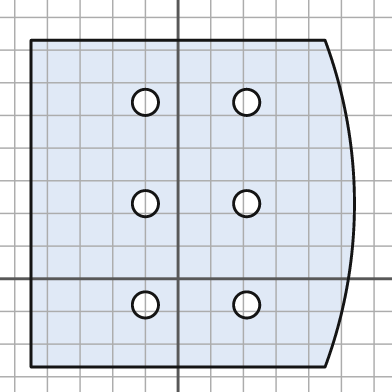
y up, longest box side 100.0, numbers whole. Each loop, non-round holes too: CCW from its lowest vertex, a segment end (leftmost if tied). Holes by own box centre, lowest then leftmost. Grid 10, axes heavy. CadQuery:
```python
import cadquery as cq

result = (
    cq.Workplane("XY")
    .moveTo(-45.0, -27.0)
    .lineTo(45.0, -27.0)
    .threePointArc((54.0, 23.0), (45.0, 73.0))
    .lineTo(-45.0, 73.0)
    .close()
    .moveTo(-10.0, -8.0)
    .circle(4.0)
    .moveTo(21.0, -8.0)
    .circle(4.0)
    .moveTo(-10.0, 23.0)
    .circle(4.0)
    .moveTo(21.0, 23.0)
    .circle(4.0)
    .moveTo(-10.0, 54.0)
    .circle(4.0)
    .moveTo(21.0, 54.0)
    .circle(4.0)
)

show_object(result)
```